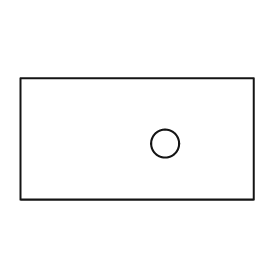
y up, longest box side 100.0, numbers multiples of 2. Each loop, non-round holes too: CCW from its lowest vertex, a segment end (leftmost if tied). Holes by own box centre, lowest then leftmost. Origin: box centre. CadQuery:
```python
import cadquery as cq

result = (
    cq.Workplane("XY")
    .moveTo(-50.0, -26.0)
    .lineTo(50.0, -26.0)
    .lineTo(50.0, 26.0)
    .lineTo(-50.0, 26.0)
    .close()
    .moveTo(12.0, -2.0)
    .circle(6.0)
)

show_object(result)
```